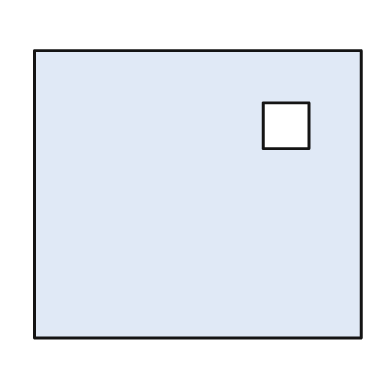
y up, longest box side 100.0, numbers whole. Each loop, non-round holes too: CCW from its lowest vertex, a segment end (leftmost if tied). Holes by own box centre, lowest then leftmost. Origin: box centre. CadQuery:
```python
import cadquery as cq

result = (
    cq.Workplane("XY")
    .moveTo(-50.0, -44.0)
    .lineTo(50.0, -44.0)
    .lineTo(50.0, 44.0)
    .lineTo(-50.0, 44.0)
    .close()
    .moveTo(20.0, 14.0)
    .lineTo(34.0, 14.0)
    .lineTo(34.0, 28.0)
    .lineTo(20.0, 28.0)
    .close()
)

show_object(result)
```